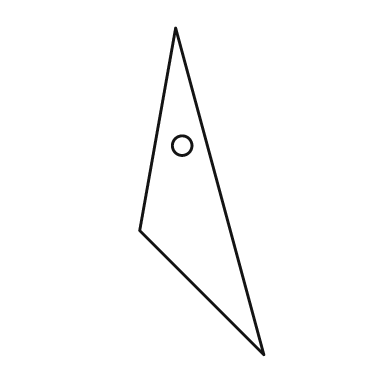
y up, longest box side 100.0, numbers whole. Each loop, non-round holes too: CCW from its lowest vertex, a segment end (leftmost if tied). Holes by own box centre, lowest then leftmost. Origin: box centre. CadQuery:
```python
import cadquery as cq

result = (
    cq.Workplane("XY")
    .moveTo(19.0, -50.0)
    .lineTo(-8.0, 50.0)
    .lineTo(-19.0, -12.0)
    .close()
    .moveTo(-6.0, 14.0)
    .circle(3.0)
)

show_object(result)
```